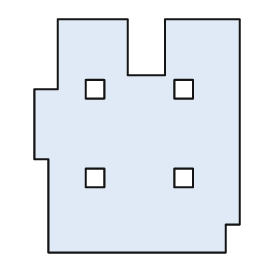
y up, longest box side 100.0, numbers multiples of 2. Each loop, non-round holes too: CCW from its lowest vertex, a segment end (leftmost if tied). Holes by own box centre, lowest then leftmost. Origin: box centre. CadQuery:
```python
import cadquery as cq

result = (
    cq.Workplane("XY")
    .moveTo(-38.0, -50.0)
    .lineTo(38.0, -50.0)
    .lineTo(38.0, -38.0)
    .lineTo(44.0, -38.0)
    .lineTo(44.0, 50.0)
    .lineTo(12.0, 50.0)
    .lineTo(12.0, 26.0)
    .lineTo(-4.0, 26.0)
    .lineTo(-4.0, 50.0)
    .lineTo(-34.0, 50.0)
    .lineTo(-34.0, 20.0)
    .lineTo(-44.0, 20.0)
    .lineTo(-44.0, -10.0)
    .lineTo(-38.0, -10.0)
    .close()
    .moveTo(-22.0, -22.0)
    .lineTo(-14.0, -22.0)
    .lineTo(-14.0, -14.0)
    .lineTo(-22.0, -14.0)
    .close()
    .moveTo(16.0, -22.0)
    .lineTo(24.0, -22.0)
    .lineTo(24.0, -14.0)
    .lineTo(16.0, -14.0)
    .close()
    .moveTo(-22.0, 16.0)
    .lineTo(-14.0, 16.0)
    .lineTo(-14.0, 24.0)
    .lineTo(-22.0, 24.0)
    .close()
    .moveTo(16.0, 16.0)
    .lineTo(24.0, 16.0)
    .lineTo(24.0, 24.0)
    .lineTo(16.0, 24.0)
    .close()
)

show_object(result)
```